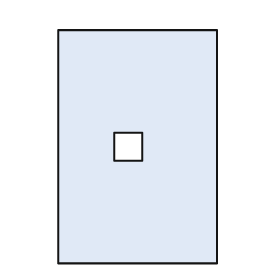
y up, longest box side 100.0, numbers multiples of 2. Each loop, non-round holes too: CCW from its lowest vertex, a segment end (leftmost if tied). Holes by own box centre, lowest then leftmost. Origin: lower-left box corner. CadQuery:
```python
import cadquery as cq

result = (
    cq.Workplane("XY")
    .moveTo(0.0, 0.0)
    .lineTo(68.0, 0.0)
    .lineTo(68.0, 100.0)
    .lineTo(0.0, 100.0)
    .close()
    .moveTo(24.0, 44.0)
    .lineTo(36.0, 44.0)
    .lineTo(36.0, 56.0)
    .lineTo(24.0, 56.0)
    .close()
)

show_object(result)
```